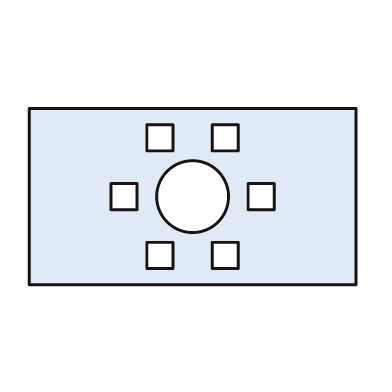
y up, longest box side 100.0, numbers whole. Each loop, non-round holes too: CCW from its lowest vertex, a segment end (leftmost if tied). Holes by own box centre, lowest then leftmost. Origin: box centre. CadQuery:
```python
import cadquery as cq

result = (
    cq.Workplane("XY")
    .moveTo(-50.0, -27.0)
    .lineTo(50.0, -27.0)
    .lineTo(50.0, 27.0)
    .lineTo(-50.0, 27.0)
    .close()
    .moveTo(-14.0, -22.0)
    .lineTo(-6.0, -22.0)
    .lineTo(-6.0, -14.0)
    .lineTo(-14.0, -14.0)
    .close()
    .moveTo(6.0, -22.0)
    .lineTo(14.0, -22.0)
    .lineTo(14.0, -14.0)
    .lineTo(6.0, -14.0)
    .close()
    .moveTo(-25.0, -4.0)
    .lineTo(-17.0, -4.0)
    .lineTo(-17.0, 4.0)
    .lineTo(-25.0, 4.0)
    .close()
    .moveTo(0.0, 0.0)
    .circle(11.0)
    .moveTo(17.0, -4.0)
    .lineTo(25.0, -4.0)
    .lineTo(25.0, 4.0)
    .lineTo(17.0, 4.0)
    .close()
    .moveTo(-14.0, 14.0)
    .lineTo(-6.0, 14.0)
    .lineTo(-6.0, 22.0)
    .lineTo(-14.0, 22.0)
    .close()
    .moveTo(6.0, 14.0)
    .lineTo(14.0, 14.0)
    .lineTo(14.0, 22.0)
    .lineTo(6.0, 22.0)
    .close()
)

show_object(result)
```